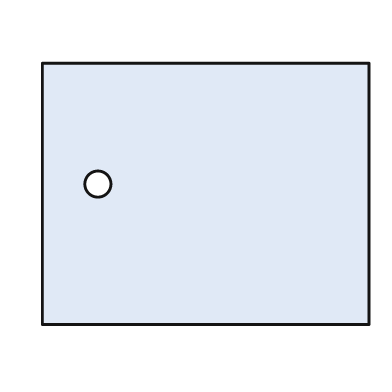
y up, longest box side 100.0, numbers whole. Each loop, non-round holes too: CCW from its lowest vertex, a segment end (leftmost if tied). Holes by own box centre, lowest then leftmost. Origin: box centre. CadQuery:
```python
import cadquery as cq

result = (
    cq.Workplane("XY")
    .moveTo(-50.0, -40.0)
    .lineTo(50.0, -40.0)
    .lineTo(50.0, 40.0)
    .lineTo(-50.0, 40.0)
    .close()
    .moveTo(-33.0, 3.0)
    .circle(4.0)
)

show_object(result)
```